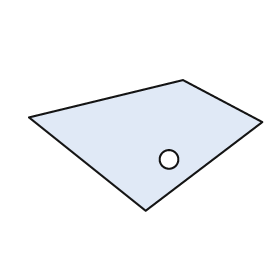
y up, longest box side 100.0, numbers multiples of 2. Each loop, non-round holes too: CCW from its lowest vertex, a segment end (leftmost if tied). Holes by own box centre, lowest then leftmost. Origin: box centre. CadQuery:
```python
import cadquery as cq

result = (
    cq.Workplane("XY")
    .moveTo(0.0, -28.0)
    .lineTo(50.0, 10.0)
    .lineTo(16.0, 28.0)
    .lineTo(-50.0, 12.0)
    .close()
    .moveTo(10.0, -6.0)
    .circle(4.0)
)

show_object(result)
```